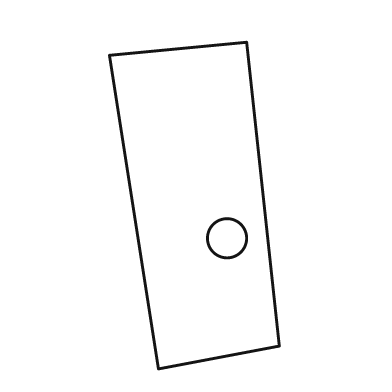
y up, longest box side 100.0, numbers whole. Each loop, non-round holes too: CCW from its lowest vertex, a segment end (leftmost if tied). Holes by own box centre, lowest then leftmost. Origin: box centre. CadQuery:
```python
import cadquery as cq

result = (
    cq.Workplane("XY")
    .moveTo(-11.0, -50.0)
    .lineTo(26.0, -43.0)
    .lineTo(16.0, 50.0)
    .lineTo(-26.0, 46.0)
    .close()
    .moveTo(10.0, -10.0)
    .circle(6.0)
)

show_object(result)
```